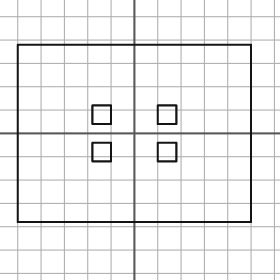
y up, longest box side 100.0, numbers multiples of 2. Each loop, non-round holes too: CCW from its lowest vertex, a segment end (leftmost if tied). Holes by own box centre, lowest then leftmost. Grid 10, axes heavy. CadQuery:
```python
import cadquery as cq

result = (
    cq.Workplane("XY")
    .moveTo(-50.0, -38.0)
    .lineTo(50.0, -38.0)
    .lineTo(50.0, 38.0)
    .lineTo(-50.0, 38.0)
    .close()
    .moveTo(-18.0, -12.0)
    .lineTo(-10.0, -12.0)
    .lineTo(-10.0, -4.0)
    .lineTo(-18.0, -4.0)
    .close()
    .moveTo(10.0, -12.0)
    .lineTo(18.0, -12.0)
    .lineTo(18.0, -4.0)
    .lineTo(10.0, -4.0)
    .close()
    .moveTo(-18.0, 4.0)
    .lineTo(-10.0, 4.0)
    .lineTo(-10.0, 12.0)
    .lineTo(-18.0, 12.0)
    .close()
    .moveTo(10.0, 4.0)
    .lineTo(18.0, 4.0)
    .lineTo(18.0, 12.0)
    .lineTo(10.0, 12.0)
    .close()
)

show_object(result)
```